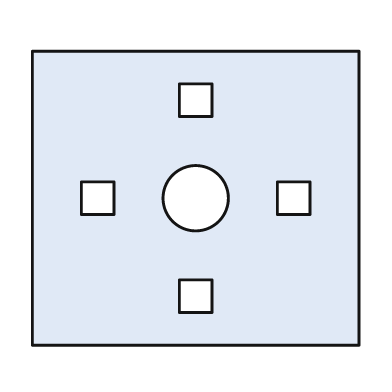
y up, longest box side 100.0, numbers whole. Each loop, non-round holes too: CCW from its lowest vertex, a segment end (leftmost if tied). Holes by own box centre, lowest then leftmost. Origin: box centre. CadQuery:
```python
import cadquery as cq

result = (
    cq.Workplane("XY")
    .moveTo(-50.0, -45.0)
    .lineTo(50.0, -45.0)
    .lineTo(50.0, 45.0)
    .lineTo(-50.0, 45.0)
    .close()
    .moveTo(-5.0, -35.0)
    .lineTo(5.0, -35.0)
    .lineTo(5.0, -25.0)
    .lineTo(-5.0, -25.0)
    .close()
    .moveTo(-35.0, -5.0)
    .lineTo(-25.0, -5.0)
    .lineTo(-25.0, 5.0)
    .lineTo(-35.0, 5.0)
    .close()
    .moveTo(0.0, 0.0)
    .circle(10.0)
    .moveTo(25.0, -5.0)
    .lineTo(35.0, -5.0)
    .lineTo(35.0, 5.0)
    .lineTo(25.0, 5.0)
    .close()
    .moveTo(-5.0, 25.0)
    .lineTo(5.0, 25.0)
    .lineTo(5.0, 35.0)
    .lineTo(-5.0, 35.0)
    .close()
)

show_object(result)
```